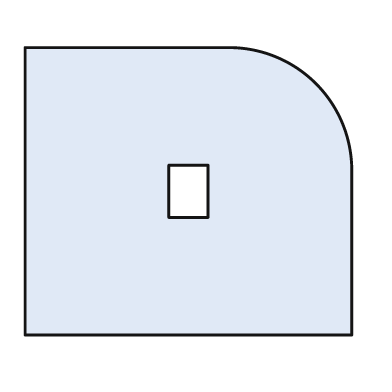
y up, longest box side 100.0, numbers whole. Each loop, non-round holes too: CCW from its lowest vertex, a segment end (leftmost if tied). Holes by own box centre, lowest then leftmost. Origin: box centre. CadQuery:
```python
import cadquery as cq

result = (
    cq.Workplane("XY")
    .moveTo(-50.0, -44.0)
    .lineTo(50.0, -44.0)
    .lineTo(50.0, 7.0)
    .threePointArc((39.0, 33.0), (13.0, 44.0))
    .lineTo(-50.0, 44.0)
    .close()
    .moveTo(-6.0, -8.0)
    .lineTo(6.0, -8.0)
    .lineTo(6.0, 8.0)
    .lineTo(-6.0, 8.0)
    .close()
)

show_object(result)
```